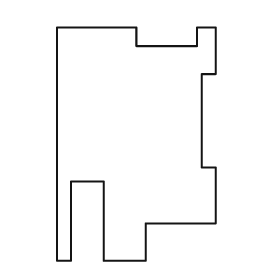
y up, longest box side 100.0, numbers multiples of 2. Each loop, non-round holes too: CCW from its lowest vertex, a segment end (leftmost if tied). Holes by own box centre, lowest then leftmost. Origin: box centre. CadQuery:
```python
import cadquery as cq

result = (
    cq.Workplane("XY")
    .moveTo(-34.0, -50.0)
    .lineTo(-28.0, -50.0)
    .lineTo(-28.0, -16.0)
    .lineTo(-14.0, -16.0)
    .lineTo(-14.0, -50.0)
    .lineTo(4.0, -50.0)
    .lineTo(4.0, -34.0)
    .lineTo(34.0, -34.0)
    .lineTo(34.0, -10.0)
    .lineTo(28.0, -10.0)
    .lineTo(28.0, 30.0)
    .lineTo(34.0, 30.0)
    .lineTo(34.0, 50.0)
    .lineTo(26.0, 50.0)
    .lineTo(26.0, 42.0)
    .lineTo(0.0, 42.0)
    .lineTo(0.0, 50.0)
    .lineTo(-34.0, 50.0)
    .close()
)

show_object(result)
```